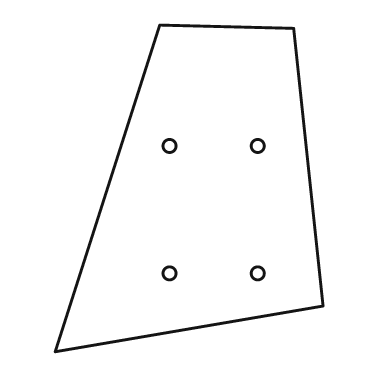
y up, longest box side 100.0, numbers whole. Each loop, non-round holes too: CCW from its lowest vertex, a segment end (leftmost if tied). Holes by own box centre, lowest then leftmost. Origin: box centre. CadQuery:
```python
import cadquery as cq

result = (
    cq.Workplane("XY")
    .moveTo(-41.0, -50.0)
    .lineTo(41.0, -36.0)
    .lineTo(32.0, 49.0)
    .lineTo(-9.0, 50.0)
    .close()
    .moveTo(-6.0, -26.0)
    .circle(2.0)
    .moveTo(21.0, -26.0)
    .circle(2.0)
    .moveTo(-6.0, 13.0)
    .circle(2.0)
    .moveTo(21.0, 13.0)
    .circle(2.0)
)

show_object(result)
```